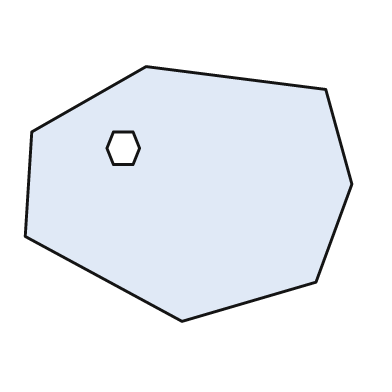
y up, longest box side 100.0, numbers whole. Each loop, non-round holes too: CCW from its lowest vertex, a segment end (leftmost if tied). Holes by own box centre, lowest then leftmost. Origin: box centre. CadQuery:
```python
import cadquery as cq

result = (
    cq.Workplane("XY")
    .moveTo(-2.0, -39.0)
    .lineTo(39.0, -27.0)
    .lineTo(50.0, 3.0)
    .lineTo(42.0, 32.0)
    .lineTo(-13.0, 39.0)
    .lineTo(-48.0, 19.0)
    .lineTo(-50.0, -13.0)
    .close()
    .moveTo(-23.0, 9.0)
    .lineTo(-17.0, 9.0)
    .lineTo(-15.0, 14.0)
    .lineTo(-17.0, 19.0)
    .lineTo(-23.0, 19.0)
    .lineTo(-25.0, 14.0)
    .close()
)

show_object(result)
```